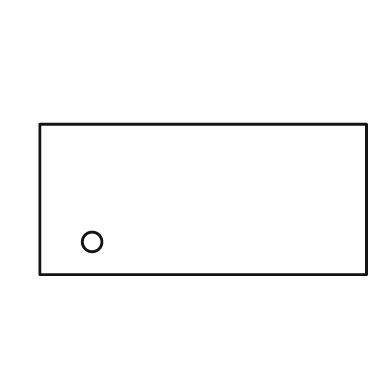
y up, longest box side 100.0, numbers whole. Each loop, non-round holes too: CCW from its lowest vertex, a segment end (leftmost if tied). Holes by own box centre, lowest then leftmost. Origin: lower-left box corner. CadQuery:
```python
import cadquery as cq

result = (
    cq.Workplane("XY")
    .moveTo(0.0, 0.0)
    .lineTo(100.0, 0.0)
    .lineTo(100.0, 46.0)
    .lineTo(0.0, 46.0)
    .close()
    .moveTo(16.0, 10.0)
    .circle(3.0)
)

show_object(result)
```